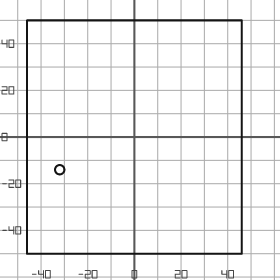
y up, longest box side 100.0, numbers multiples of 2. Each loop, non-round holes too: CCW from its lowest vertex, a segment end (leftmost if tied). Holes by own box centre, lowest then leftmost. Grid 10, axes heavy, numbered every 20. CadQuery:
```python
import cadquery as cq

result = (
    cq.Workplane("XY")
    .moveTo(-46.0, -50.0)
    .lineTo(46.0, -50.0)
    .lineTo(46.0, 50.0)
    .lineTo(-46.0, 50.0)
    .close()
    .moveTo(-32.0, -14.0)
    .circle(2.0)
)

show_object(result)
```